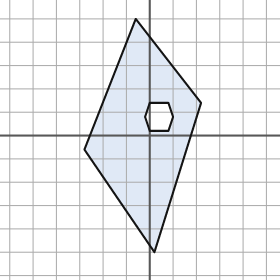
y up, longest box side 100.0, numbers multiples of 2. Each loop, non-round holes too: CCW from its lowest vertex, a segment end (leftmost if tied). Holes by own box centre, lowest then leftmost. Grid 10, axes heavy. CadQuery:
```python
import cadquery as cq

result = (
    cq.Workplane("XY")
    .moveTo(2.0, -50.0)
    .lineTo(22.0, 14.0)
    .lineTo(-6.0, 50.0)
    .lineTo(-28.0, -6.0)
    .close()
    .moveTo(0.0, 2.0)
    .lineTo(8.0, 2.0)
    .lineTo(10.0, 8.0)
    .lineTo(8.0, 14.0)
    .lineTo(0.0, 14.0)
    .lineTo(-2.0, 8.0)
    .close()
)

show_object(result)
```